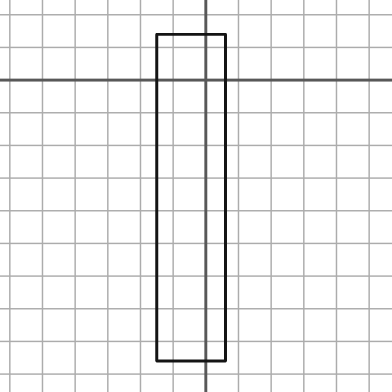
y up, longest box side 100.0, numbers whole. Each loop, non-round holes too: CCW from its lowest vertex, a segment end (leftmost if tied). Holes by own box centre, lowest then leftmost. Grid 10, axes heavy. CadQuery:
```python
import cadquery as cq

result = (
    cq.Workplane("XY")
    .moveTo(-15.0, -86.0)
    .lineTo(6.0, -86.0)
    .lineTo(6.0, 14.0)
    .lineTo(-15.0, 14.0)
    .close()
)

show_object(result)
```